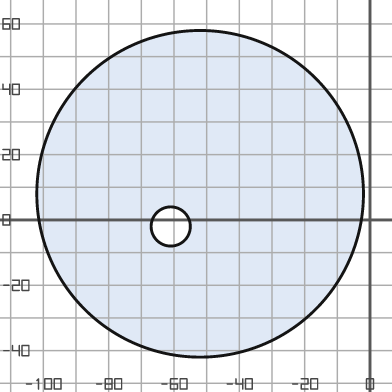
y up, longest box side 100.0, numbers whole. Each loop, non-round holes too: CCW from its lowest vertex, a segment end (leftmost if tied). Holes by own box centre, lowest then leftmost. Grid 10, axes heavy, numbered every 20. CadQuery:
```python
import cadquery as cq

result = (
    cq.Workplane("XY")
    .moveTo(-52.0, 8.0)
    .circle(50.0)
    .moveTo(-61.0, -2.0)
    .circle(6.0)
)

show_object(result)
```